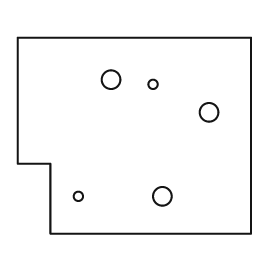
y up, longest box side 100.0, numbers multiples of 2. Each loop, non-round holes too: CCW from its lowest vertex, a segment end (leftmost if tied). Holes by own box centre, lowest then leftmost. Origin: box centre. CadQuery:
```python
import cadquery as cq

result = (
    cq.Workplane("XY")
    .moveTo(-36.0, -42.0)
    .lineTo(50.0, -42.0)
    .lineTo(50.0, 42.0)
    .lineTo(-50.0, 42.0)
    .lineTo(-50.0, -12.0)
    .lineTo(-36.0, -12.0)
    .close()
    .moveTo(-24.0, -26.0)
    .circle(2.0)
    .moveTo(12.0, -26.0)
    .circle(4.0)
    .moveTo(32.0, 10.0)
    .circle(4.0)
    .moveTo(8.0, 22.0)
    .circle(2.0)
    .moveTo(-10.0, 24.0)
    .circle(4.0)
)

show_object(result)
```